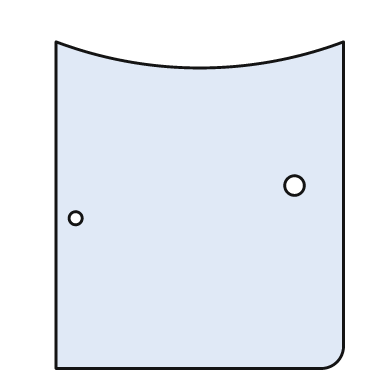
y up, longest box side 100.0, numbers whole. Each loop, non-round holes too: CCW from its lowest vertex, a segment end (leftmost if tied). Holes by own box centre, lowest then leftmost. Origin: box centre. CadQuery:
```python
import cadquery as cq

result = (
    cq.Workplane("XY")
    .moveTo(-44.0, -50.0)
    .lineTo(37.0, -50.0)
    .threePointArc((42.0, -48.0), (44.0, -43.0))
    .lineTo(44.0, 50.0)
    .threePointArc((0.0, 42.0), (-44.0, 50.0))
    .close()
    .moveTo(-38.0, -4.0)
    .circle(2.0)
    .moveTo(29.0, 6.0)
    .circle(3.0)
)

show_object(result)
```